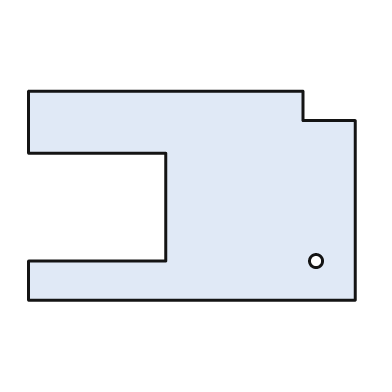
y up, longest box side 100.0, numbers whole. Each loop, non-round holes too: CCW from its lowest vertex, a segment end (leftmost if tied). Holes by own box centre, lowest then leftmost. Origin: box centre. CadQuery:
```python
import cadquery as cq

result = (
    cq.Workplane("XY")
    .moveTo(-50.0, -32.0)
    .lineTo(50.0, -32.0)
    .lineTo(50.0, 23.0)
    .lineTo(34.0, 23.0)
    .lineTo(34.0, 32.0)
    .lineTo(-50.0, 32.0)
    .lineTo(-50.0, 13.0)
    .lineTo(-8.0, 13.0)
    .lineTo(-8.0, -20.0)
    .lineTo(-50.0, -20.0)
    .close()
    .moveTo(38.0, -20.0)
    .circle(2.0)
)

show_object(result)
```